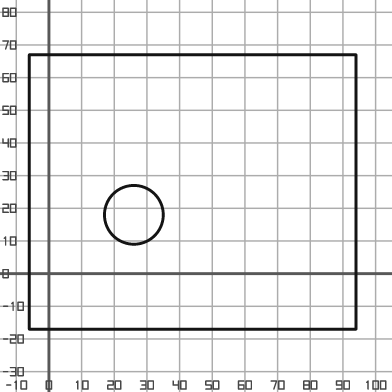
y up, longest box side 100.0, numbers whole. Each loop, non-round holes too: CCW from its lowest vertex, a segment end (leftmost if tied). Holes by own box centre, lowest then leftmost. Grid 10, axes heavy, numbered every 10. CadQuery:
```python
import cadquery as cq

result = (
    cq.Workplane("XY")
    .moveTo(-6.0, -17.0)
    .lineTo(94.0, -17.0)
    .lineTo(94.0, 67.0)
    .lineTo(-6.0, 67.0)
    .close()
    .moveTo(26.0, 18.0)
    .circle(9.0)
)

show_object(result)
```